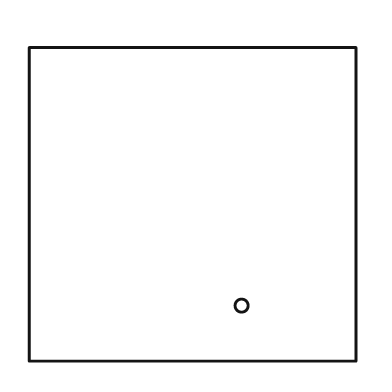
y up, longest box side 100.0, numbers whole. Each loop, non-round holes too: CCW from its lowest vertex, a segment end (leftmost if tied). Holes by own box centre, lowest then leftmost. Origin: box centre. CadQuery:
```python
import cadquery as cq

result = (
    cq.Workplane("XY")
    .moveTo(-50.0, -48.0)
    .lineTo(50.0, -48.0)
    .lineTo(50.0, 48.0)
    .lineTo(-50.0, 48.0)
    .close()
    .moveTo(15.0, -31.0)
    .circle(2.0)
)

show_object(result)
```